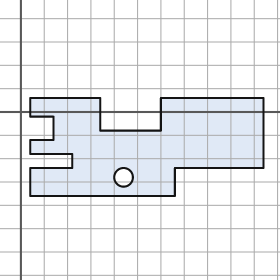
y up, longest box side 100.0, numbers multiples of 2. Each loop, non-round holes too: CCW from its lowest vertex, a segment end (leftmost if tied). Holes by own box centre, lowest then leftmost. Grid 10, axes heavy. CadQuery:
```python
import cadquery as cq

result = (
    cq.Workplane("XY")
    .moveTo(4.0, -36.0)
    .lineTo(66.0, -36.0)
    .lineTo(66.0, -24.0)
    .lineTo(104.0, -24.0)
    .lineTo(104.0, 6.0)
    .lineTo(60.0, 6.0)
    .lineTo(60.0, -8.0)
    .lineTo(34.0, -8.0)
    .lineTo(34.0, 6.0)
    .lineTo(4.0, 6.0)
    .lineTo(4.0, -2.0)
    .lineTo(14.0, -2.0)
    .lineTo(14.0, -12.0)
    .lineTo(4.0, -12.0)
    .lineTo(4.0, -18.0)
    .lineTo(22.0, -18.0)
    .lineTo(22.0, -24.0)
    .lineTo(4.0, -24.0)
    .close()
    .moveTo(44.0, -28.0)
    .circle(4.0)
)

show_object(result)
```